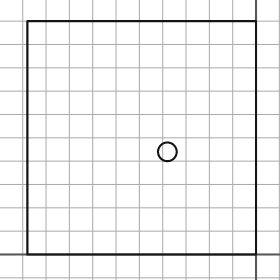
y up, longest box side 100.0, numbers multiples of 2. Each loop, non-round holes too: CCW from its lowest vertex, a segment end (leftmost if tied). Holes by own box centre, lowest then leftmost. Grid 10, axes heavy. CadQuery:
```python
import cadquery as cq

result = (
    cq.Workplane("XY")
    .moveTo(-98.0, 0.0)
    .lineTo(0.0, 0.0)
    .lineTo(0.0, 100.0)
    .lineTo(-98.0, 100.0)
    .close()
    .moveTo(-38.0, 44.0)
    .circle(4.0)
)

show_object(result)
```